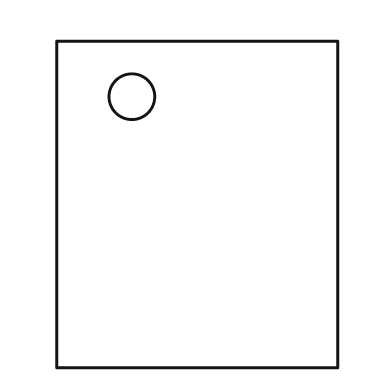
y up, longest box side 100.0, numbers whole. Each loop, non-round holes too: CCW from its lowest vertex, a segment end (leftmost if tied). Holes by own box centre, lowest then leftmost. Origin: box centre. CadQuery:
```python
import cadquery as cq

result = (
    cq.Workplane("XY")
    .moveTo(-43.0, -50.0)
    .lineTo(43.0, -50.0)
    .lineTo(43.0, 50.0)
    .lineTo(-43.0, 50.0)
    .close()
    .moveTo(-20.0, 33.0)
    .circle(7.0)
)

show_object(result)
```